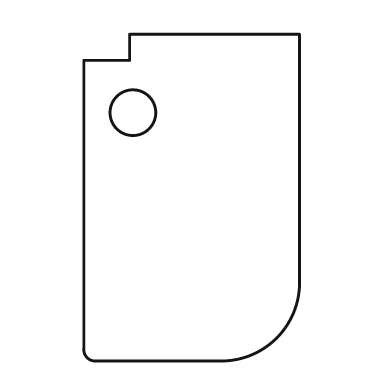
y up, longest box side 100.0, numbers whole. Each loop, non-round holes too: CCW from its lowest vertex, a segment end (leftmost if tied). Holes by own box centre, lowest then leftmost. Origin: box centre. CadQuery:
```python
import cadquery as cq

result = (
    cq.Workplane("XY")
    .moveTo(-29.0, -50.0)
    .lineTo(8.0, -50.0)
    .threePointArc((26.0, -43.0), (33.0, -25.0))
    .lineTo(33.0, 50.0)
    .lineTo(-19.0, 50.0)
    .lineTo(-19.0, 42.0)
    .lineTo(-33.0, 42.0)
    .lineTo(-33.0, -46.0)
    .threePointArc((-32.0, -49.0), (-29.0, -50.0))
    .close()
    .moveTo(-18.0, 26.0)
    .circle(7.0)
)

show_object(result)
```